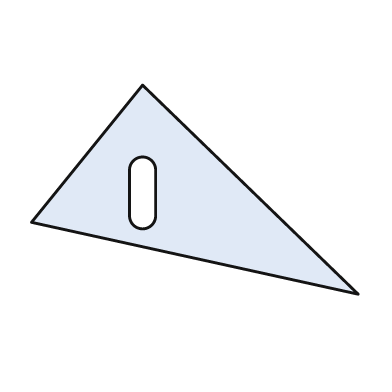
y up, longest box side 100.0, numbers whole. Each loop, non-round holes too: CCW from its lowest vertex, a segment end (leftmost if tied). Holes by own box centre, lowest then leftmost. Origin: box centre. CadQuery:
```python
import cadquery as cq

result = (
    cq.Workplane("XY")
    .moveTo(50.0, -32.0)
    .lineTo(-16.0, 32.0)
    .lineTo(-50.0, -10.0)
    .close()
    .moveTo(-20.0, -8.0)
    .threePointArc((-16.0, -12.0), (-12.0, -8.0))
    .lineTo(-12.0, 6.0)
    .threePointArc((-16.0, 10.0), (-20.0, 6.0))
    .close()
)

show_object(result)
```